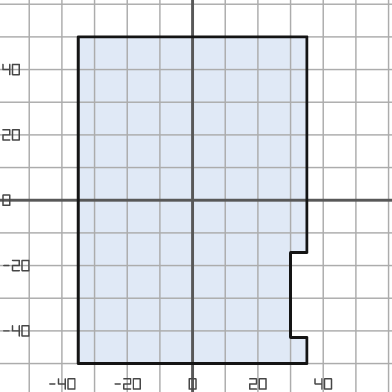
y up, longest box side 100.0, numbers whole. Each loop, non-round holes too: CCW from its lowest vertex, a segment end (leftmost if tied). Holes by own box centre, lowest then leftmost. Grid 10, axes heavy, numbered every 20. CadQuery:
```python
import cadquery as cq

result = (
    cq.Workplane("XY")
    .moveTo(-35.0, -50.0)
    .lineTo(35.0, -50.0)
    .lineTo(35.0, -42.0)
    .lineTo(30.0, -42.0)
    .lineTo(30.0, -16.0)
    .lineTo(35.0, -16.0)
    .lineTo(35.0, 50.0)
    .lineTo(-35.0, 50.0)
    .close()
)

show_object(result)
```